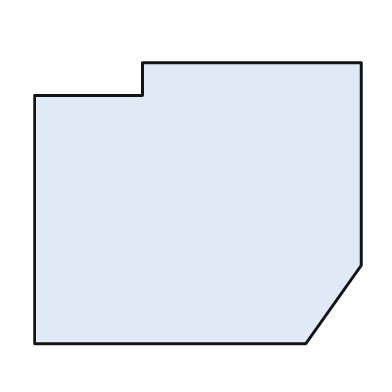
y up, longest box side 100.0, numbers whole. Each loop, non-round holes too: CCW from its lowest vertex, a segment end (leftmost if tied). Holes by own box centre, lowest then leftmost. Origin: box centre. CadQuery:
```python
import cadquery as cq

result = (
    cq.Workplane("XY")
    .moveTo(-50.0, -43.0)
    .lineTo(33.0, -43.0)
    .lineTo(50.0, -19.0)
    .lineTo(50.0, 43.0)
    .lineTo(-17.0, 43.0)
    .lineTo(-17.0, 33.0)
    .lineTo(-50.0, 33.0)
    .close()
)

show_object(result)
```